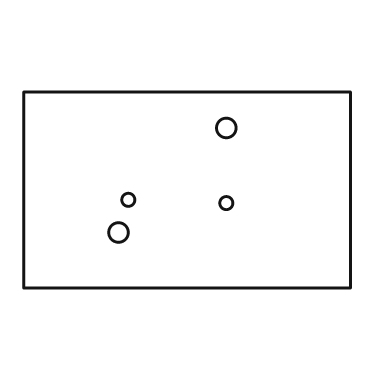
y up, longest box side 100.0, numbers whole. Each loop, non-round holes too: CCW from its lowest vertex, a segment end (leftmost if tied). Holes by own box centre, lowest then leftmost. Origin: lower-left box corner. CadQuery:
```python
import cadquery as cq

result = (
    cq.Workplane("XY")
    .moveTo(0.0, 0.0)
    .lineTo(100.0, 0.0)
    .lineTo(100.0, 60.0)
    .lineTo(0.0, 60.0)
    .close()
    .moveTo(29.0, 17.0)
    .circle(3.0)
    .moveTo(62.0, 26.0)
    .circle(2.0)
    .moveTo(32.0, 27.0)
    .circle(2.0)
    .moveTo(62.0, 49.0)
    .circle(3.0)
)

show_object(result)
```